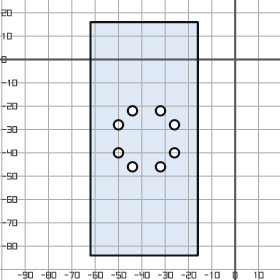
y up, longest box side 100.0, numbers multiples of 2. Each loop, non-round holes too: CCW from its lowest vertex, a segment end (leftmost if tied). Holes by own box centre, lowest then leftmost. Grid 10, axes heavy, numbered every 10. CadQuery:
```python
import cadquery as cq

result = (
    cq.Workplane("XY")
    .moveTo(-62.0, -84.0)
    .lineTo(-16.0, -84.0)
    .lineTo(-16.0, 16.0)
    .lineTo(-62.0, 16.0)
    .close()
    .moveTo(-44.0, -46.0)
    .circle(2.0)
    .moveTo(-32.0, -46.0)
    .circle(2.0)
    .moveTo(-50.0, -40.0)
    .circle(2.0)
    .moveTo(-26.0, -40.0)
    .circle(2.0)
    .moveTo(-50.0, -28.0)
    .circle(2.0)
    .moveTo(-26.0, -28.0)
    .circle(2.0)
    .moveTo(-44.0, -22.0)
    .circle(2.0)
    .moveTo(-32.0, -22.0)
    .circle(2.0)
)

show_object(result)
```